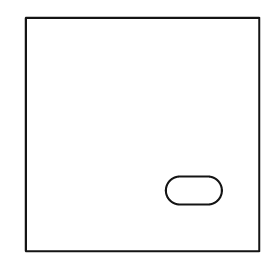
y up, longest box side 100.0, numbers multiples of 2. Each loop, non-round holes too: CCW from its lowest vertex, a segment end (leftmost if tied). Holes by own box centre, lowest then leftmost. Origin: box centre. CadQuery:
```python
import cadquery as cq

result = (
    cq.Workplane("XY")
    .moveTo(-50.0, -50.0)
    .lineTo(50.0, -50.0)
    .lineTo(50.0, 50.0)
    .lineTo(-50.0, 50.0)
    .close()
    .moveTo(16.0, -30.0)
    .lineTo(28.0, -30.0)
    .threePointArc((34.0, -24.0), (28.0, -18.0))
    .lineTo(16.0, -18.0)
    .threePointArc((10.0, -24.0), (16.0, -30.0))
    .close()
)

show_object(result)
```